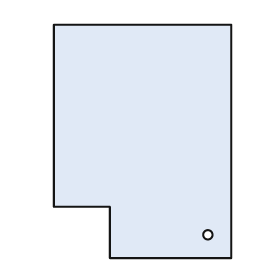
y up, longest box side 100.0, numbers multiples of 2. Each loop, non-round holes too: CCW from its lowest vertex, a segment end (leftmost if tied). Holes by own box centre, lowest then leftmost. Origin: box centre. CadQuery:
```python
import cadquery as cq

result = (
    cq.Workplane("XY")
    .moveTo(-14.0, -50.0)
    .lineTo(38.0, -50.0)
    .lineTo(38.0, 50.0)
    .lineTo(-38.0, 50.0)
    .lineTo(-38.0, -28.0)
    .lineTo(-14.0, -28.0)
    .close()
    .moveTo(28.0, -40.0)
    .circle(2.0)
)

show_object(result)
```